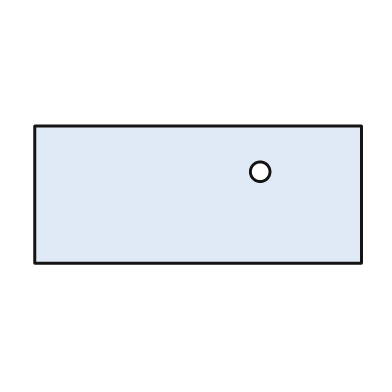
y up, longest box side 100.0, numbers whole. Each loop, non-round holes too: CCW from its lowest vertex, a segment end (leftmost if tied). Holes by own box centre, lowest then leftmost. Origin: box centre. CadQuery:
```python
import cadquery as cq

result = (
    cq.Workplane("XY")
    .moveTo(-50.0, -21.0)
    .lineTo(50.0, -21.0)
    .lineTo(50.0, 21.0)
    .lineTo(-50.0, 21.0)
    .close()
    .moveTo(19.0, 7.0)
    .circle(3.0)
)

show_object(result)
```